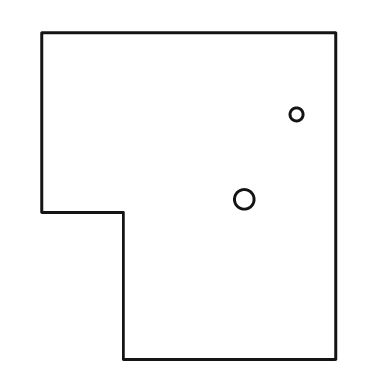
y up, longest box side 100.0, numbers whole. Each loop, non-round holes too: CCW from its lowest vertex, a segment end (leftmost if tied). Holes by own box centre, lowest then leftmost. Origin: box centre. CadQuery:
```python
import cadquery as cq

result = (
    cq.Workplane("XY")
    .moveTo(-20.0, -50.0)
    .lineTo(45.0, -50.0)
    .lineTo(45.0, 50.0)
    .lineTo(-45.0, 50.0)
    .lineTo(-45.0, -5.0)
    .lineTo(-20.0, -5.0)
    .close()
    .moveTo(17.0, -1.0)
    .circle(3.0)
    .moveTo(33.0, 25.0)
    .circle(2.0)
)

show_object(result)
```